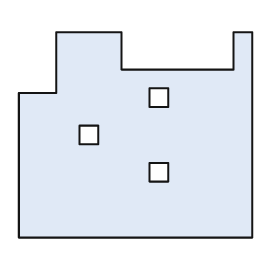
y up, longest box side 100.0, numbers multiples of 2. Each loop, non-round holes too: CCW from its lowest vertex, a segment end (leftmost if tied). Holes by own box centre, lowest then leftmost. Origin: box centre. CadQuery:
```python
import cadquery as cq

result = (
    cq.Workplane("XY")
    .moveTo(-50.0, -44.0)
    .lineTo(50.0, -44.0)
    .lineTo(50.0, 44.0)
    .lineTo(42.0, 44.0)
    .lineTo(42.0, 28.0)
    .lineTo(-6.0, 28.0)
    .lineTo(-6.0, 44.0)
    .lineTo(-34.0, 44.0)
    .lineTo(-34.0, 18.0)
    .lineTo(-50.0, 18.0)
    .close()
    .moveTo(6.0, -20.0)
    .lineTo(14.0, -20.0)
    .lineTo(14.0, -12.0)
    .lineTo(6.0, -12.0)
    .close()
    .moveTo(-24.0, -4.0)
    .lineTo(-16.0, -4.0)
    .lineTo(-16.0, 4.0)
    .lineTo(-24.0, 4.0)
    .close()
    .moveTo(6.0, 12.0)
    .lineTo(14.0, 12.0)
    .lineTo(14.0, 20.0)
    .lineTo(6.0, 20.0)
    .close()
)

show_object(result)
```